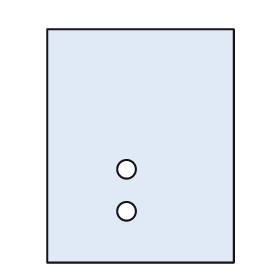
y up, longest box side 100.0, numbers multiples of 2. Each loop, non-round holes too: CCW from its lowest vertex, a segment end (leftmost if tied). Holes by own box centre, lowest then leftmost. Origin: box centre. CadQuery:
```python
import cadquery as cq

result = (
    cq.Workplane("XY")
    .moveTo(-40.0, -50.0)
    .lineTo(40.0, -50.0)
    .lineTo(40.0, 50.0)
    .lineTo(-40.0, 50.0)
    .close()
    .moveTo(-6.0, -28.0)
    .circle(4.0)
    .moveTo(-6.0, -10.0)
    .circle(4.0)
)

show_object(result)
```